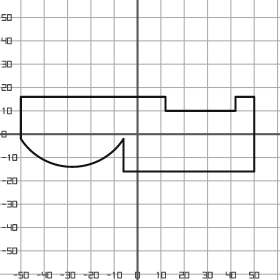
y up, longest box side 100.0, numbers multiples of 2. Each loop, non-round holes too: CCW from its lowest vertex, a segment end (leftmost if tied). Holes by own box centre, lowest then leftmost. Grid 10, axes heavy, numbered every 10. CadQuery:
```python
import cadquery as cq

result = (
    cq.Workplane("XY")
    .moveTo(-6.0, -16.0)
    .lineTo(50.0, -16.0)
    .lineTo(50.0, 16.0)
    .lineTo(42.0, 16.0)
    .lineTo(42.0, 10.0)
    .lineTo(12.0, 10.0)
    .lineTo(12.0, 16.0)
    .lineTo(-50.0, 16.0)
    .lineTo(-50.0, -2.0)
    .threePointArc((-28.0, -14.0), (-6.0, -2.0))
    .close()
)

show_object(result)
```